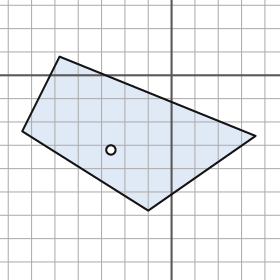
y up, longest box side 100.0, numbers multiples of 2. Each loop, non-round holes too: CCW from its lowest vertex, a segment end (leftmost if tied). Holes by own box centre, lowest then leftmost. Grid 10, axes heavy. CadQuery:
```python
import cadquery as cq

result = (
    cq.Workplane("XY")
    .moveTo(-10.0, -58.0)
    .lineTo(36.0, -26.0)
    .lineTo(-48.0, 8.0)
    .lineTo(-64.0, -24.0)
    .close()
    .moveTo(-26.0, -32.0)
    .circle(2.0)
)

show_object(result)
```